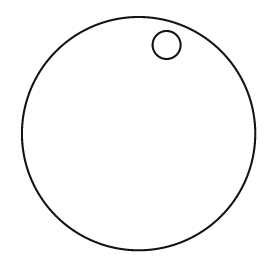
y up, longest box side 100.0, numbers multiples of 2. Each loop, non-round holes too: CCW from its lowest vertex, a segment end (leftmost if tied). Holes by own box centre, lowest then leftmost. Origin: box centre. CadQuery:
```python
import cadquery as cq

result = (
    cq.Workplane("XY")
    .moveTo(0.0, 0.0)
    .circle(50.0)
    .moveTo(12.0, 38.0)
    .circle(6.0)
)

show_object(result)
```